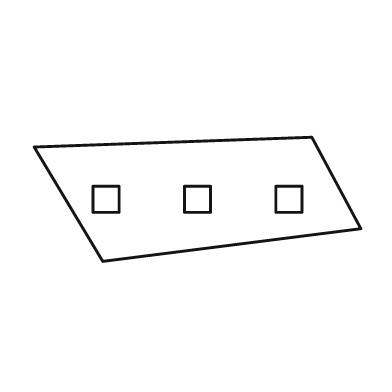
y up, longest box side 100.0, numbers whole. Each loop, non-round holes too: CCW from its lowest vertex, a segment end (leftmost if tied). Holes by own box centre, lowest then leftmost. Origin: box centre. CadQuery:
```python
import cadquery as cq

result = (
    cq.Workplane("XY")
    .moveTo(-29.0, -19.0)
    .lineTo(50.0, -9.0)
    .lineTo(35.0, 19.0)
    .lineTo(-50.0, 16.0)
    .close()
    .moveTo(-32.0, -4.0)
    .lineTo(-24.0, -4.0)
    .lineTo(-24.0, 4.0)
    .lineTo(-32.0, 4.0)
    .close()
    .moveTo(-4.0, -4.0)
    .lineTo(4.0, -4.0)
    .lineTo(4.0, 4.0)
    .lineTo(-4.0, 4.0)
    .close()
    .moveTo(24.0, -4.0)
    .lineTo(32.0, -4.0)
    .lineTo(32.0, 4.0)
    .lineTo(24.0, 4.0)
    .close()
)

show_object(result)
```